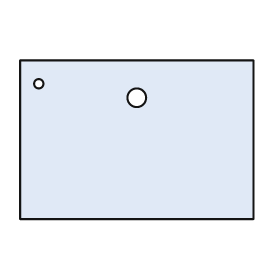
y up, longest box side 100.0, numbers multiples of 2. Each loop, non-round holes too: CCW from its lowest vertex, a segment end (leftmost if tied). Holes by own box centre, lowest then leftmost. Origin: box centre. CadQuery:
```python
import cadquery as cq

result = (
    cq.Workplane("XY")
    .moveTo(-50.0, -34.0)
    .lineTo(50.0, -34.0)
    .lineTo(50.0, 34.0)
    .lineTo(-50.0, 34.0)
    .close()
    .moveTo(0.0, 18.0)
    .circle(4.0)
    .moveTo(-42.0, 24.0)
    .circle(2.0)
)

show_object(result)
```